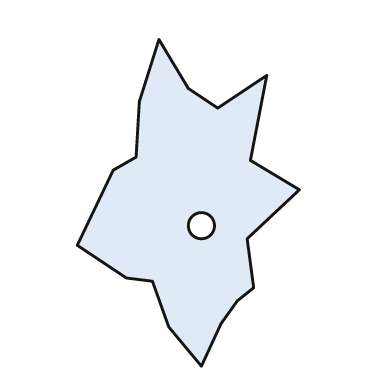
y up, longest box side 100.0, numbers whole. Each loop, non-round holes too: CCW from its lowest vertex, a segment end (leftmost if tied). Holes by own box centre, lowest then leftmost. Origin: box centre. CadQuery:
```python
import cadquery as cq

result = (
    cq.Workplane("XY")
    .moveTo(4.0, -50.0)
    .lineTo(10.0, -37.0)
    .lineTo(15.0, -30.0)
    .lineTo(20.0, -26.0)
    .lineTo(18.0, -11.0)
    .lineTo(34.0, 4.0)
    .lineTo(19.0, 13.0)
    .lineTo(24.0, 39.0)
    .lineTo(9.0, 29.0)
    .lineTo(0.0, 35.0)
    .lineTo(-9.0, 50.0)
    .lineTo(-15.0, 31.0)
    .lineTo(-16.0, 14.0)
    .lineTo(-23.0, 10.0)
    .lineTo(-34.0, -13.0)
    .lineTo(-19.0, -23.0)
    .lineTo(-11.0, -24.0)
    .lineTo(-6.0, -38.0)
    .close()
    .moveTo(4.0, -7.0)
    .circle(4.0)
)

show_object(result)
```